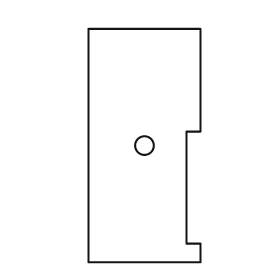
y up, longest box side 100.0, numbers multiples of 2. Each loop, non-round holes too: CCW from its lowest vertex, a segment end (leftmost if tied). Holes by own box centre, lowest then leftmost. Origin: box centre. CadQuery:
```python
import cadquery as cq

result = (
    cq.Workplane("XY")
    .moveTo(-24.0, -50.0)
    .lineTo(24.0, -50.0)
    .lineTo(24.0, -42.0)
    .lineTo(18.0, -42.0)
    .lineTo(18.0, 6.0)
    .lineTo(24.0, 6.0)
    .lineTo(24.0, 50.0)
    .lineTo(-24.0, 50.0)
    .close()
    .moveTo(0.0, 0.0)
    .circle(4.0)
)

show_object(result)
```